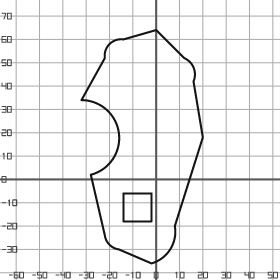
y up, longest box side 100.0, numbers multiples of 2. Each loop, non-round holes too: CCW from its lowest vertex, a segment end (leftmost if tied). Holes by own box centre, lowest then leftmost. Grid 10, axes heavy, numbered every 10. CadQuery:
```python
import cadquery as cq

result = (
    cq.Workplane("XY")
    .moveTo(-2.0, -36.0)
    .threePointArc((6.0, -30.0), (8.0, -20.0))
    .lineTo(20.0, 18.0)
    .lineTo(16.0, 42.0)
    .threePointArc((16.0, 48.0), (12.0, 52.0))
    .lineTo(0.0, 64.0)
    .lineTo(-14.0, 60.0)
    .threePointArc((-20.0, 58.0), (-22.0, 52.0))
    .lineTo(-32.0, 34.0)
    .threePointArc((-16.0, 20.0), (-28.0, 2.0))
    .lineTo(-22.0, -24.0)
    .threePointArc((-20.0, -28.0), (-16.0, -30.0))
    .close()
    .moveTo(-14.0, -18.0)
    .lineTo(-2.0, -18.0)
    .lineTo(-2.0, -6.0)
    .lineTo(-14.0, -6.0)
    .close()
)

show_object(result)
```